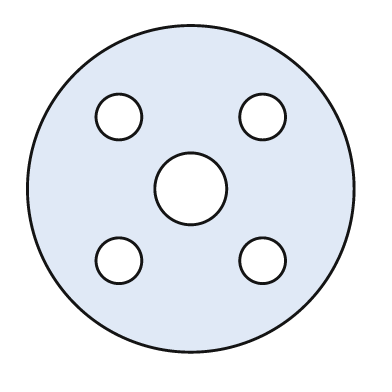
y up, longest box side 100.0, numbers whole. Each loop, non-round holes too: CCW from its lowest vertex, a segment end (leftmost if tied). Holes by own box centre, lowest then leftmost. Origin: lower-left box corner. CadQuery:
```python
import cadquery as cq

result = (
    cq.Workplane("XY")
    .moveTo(50.0, 50.0)
    .circle(50.0)
    .moveTo(28.0, 28.0)
    .circle(7.0)
    .moveTo(72.0, 28.0)
    .circle(7.0)
    .moveTo(50.0, 50.0)
    .circle(11.0)
    .moveTo(28.0, 72.0)
    .circle(7.0)
    .moveTo(72.0, 72.0)
    .circle(7.0)
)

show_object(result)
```